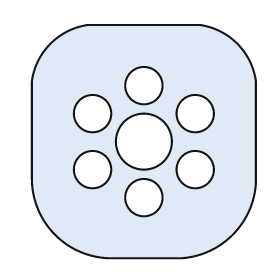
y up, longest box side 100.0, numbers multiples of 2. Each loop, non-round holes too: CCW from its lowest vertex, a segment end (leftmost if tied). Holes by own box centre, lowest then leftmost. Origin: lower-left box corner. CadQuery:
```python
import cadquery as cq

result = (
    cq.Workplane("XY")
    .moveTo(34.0, 0.0)
    .lineTo(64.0, 0.0)
    .threePointArc((86.0, 10.0), (96.0, 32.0))
    .lineTo(96.0, 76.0)
    .threePointArc((88.0, 92.0), (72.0, 100.0))
    .lineTo(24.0, 100.0)
    .threePointArc((8.0, 92.0), (0.0, 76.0))
    .lineTo(0.0, 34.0)
    .threePointArc((10.0, 10.0), (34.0, 0.0))
    .close()
    .moveTo(48.0, 26.0)
    .circle(8.0)
    .moveTo(26.0, 38.0)
    .circle(8.0)
    .moveTo(70.0, 38.0)
    .circle(8.0)
    .moveTo(48.0, 50.0)
    .circle(12.0)
    .moveTo(26.0, 62.0)
    .circle(8.0)
    .moveTo(70.0, 62.0)
    .circle(8.0)
    .moveTo(48.0, 74.0)
    .circle(8.0)
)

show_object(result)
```